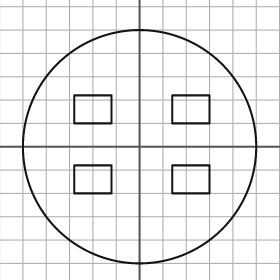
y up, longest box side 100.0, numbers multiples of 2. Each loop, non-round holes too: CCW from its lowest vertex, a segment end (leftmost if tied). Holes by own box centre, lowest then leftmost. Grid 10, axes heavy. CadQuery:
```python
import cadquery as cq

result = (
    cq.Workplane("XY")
    .moveTo(0.0, 0.0)
    .circle(50.0)
    .moveTo(-28.0, -20.0)
    .lineTo(-12.0, -20.0)
    .lineTo(-12.0, -8.0)
    .lineTo(-28.0, -8.0)
    .close()
    .moveTo(14.0, -20.0)
    .lineTo(30.0, -20.0)
    .lineTo(30.0, -8.0)
    .lineTo(14.0, -8.0)
    .close()
    .moveTo(-28.0, 10.0)
    .lineTo(-12.0, 10.0)
    .lineTo(-12.0, 22.0)
    .lineTo(-28.0, 22.0)
    .close()
    .moveTo(14.0, 10.0)
    .lineTo(30.0, 10.0)
    .lineTo(30.0, 22.0)
    .lineTo(14.0, 22.0)
    .close()
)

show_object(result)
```